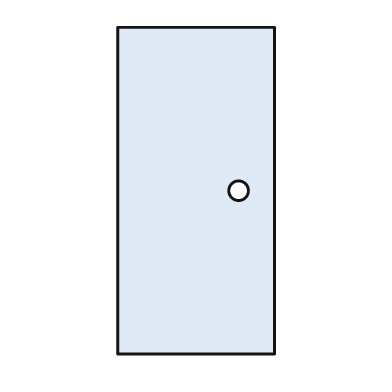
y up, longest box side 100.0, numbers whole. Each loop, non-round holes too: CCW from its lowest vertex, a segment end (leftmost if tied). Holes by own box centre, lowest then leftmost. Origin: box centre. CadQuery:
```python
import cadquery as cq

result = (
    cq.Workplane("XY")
    .moveTo(-24.0, -50.0)
    .lineTo(24.0, -50.0)
    .lineTo(24.0, 50.0)
    .lineTo(-24.0, 50.0)
    .close()
    .moveTo(13.0, 0.0)
    .circle(3.0)
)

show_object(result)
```